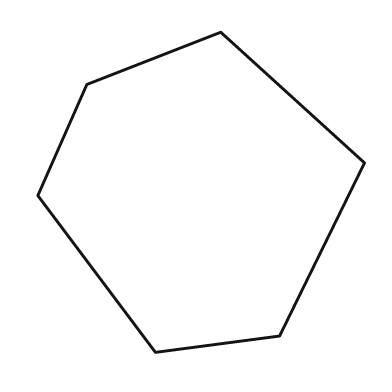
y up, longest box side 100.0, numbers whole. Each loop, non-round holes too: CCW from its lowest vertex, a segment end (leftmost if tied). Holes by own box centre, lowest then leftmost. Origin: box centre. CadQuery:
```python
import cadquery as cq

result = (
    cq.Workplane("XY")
    .moveTo(-14.0, -49.0)
    .lineTo(24.0, -44.0)
    .lineTo(50.0, 9.0)
    .lineTo(6.0, 49.0)
    .lineTo(-35.0, 33.0)
    .lineTo(-50.0, -1.0)
    .close()
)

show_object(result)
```